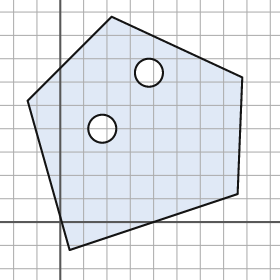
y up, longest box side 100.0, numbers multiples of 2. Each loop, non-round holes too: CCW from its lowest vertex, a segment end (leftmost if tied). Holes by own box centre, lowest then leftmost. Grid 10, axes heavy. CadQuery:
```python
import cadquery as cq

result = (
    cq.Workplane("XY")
    .moveTo(4.0, -12.0)
    .lineTo(76.0, 12.0)
    .lineTo(78.0, 62.0)
    .lineTo(22.0, 88.0)
    .lineTo(-14.0, 52.0)
    .close()
    .moveTo(18.0, 40.0)
    .circle(6.0)
    .moveTo(38.0, 64.0)
    .circle(6.0)
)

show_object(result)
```